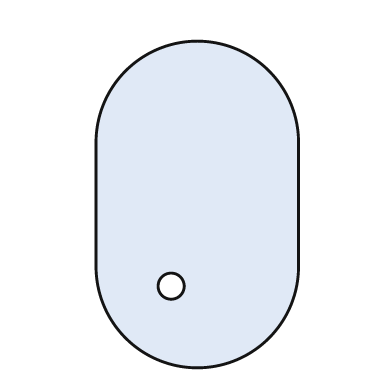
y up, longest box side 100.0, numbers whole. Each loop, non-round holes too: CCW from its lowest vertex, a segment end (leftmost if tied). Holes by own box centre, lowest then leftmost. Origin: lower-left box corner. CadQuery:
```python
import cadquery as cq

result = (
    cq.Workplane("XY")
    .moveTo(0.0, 31.0)
    .threePointArc((31.0, 0.0), (62.0, 31.0))
    .lineTo(62.0, 69.0)
    .threePointArc((31.0, 100.0), (0.0, 69.0))
    .close()
    .moveTo(23.0, 25.0)
    .circle(4.0)
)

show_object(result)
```